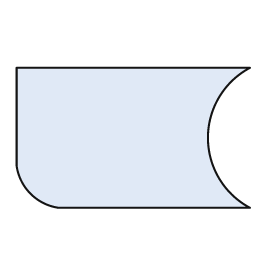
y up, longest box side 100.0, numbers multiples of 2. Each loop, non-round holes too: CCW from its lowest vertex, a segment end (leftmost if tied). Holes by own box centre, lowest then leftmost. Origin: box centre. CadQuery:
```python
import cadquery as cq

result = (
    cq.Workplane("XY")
    .moveTo(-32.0, -30.0)
    .lineTo(50.0, -30.0)
    .threePointArc((32.0, 0.0), (50.0, 30.0))
    .lineTo(-50.0, 30.0)
    .lineTo(-50.0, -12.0)
    .threePointArc((-44.0, -24.0), (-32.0, -30.0))
    .close()
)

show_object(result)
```